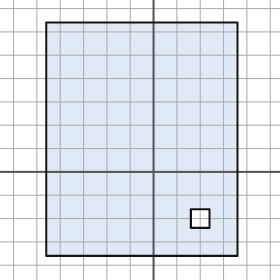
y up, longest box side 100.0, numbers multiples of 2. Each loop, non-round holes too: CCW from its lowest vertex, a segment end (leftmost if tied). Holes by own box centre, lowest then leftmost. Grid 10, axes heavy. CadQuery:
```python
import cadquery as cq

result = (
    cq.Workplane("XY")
    .moveTo(-46.0, -36.0)
    .lineTo(36.0, -36.0)
    .lineTo(36.0, 64.0)
    .lineTo(-46.0, 64.0)
    .close()
    .moveTo(16.0, -24.0)
    .lineTo(24.0, -24.0)
    .lineTo(24.0, -16.0)
    .lineTo(16.0, -16.0)
    .close()
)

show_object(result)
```